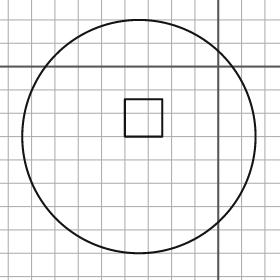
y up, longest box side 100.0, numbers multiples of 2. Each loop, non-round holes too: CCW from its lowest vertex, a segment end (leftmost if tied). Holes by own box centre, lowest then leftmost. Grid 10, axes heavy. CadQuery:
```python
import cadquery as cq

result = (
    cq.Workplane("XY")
    .moveTo(-34.0, -30.0)
    .circle(50.0)
    .moveTo(-40.0, -30.0)
    .lineTo(-24.0, -30.0)
    .lineTo(-24.0, -14.0)
    .lineTo(-40.0, -14.0)
    .close()
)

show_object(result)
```